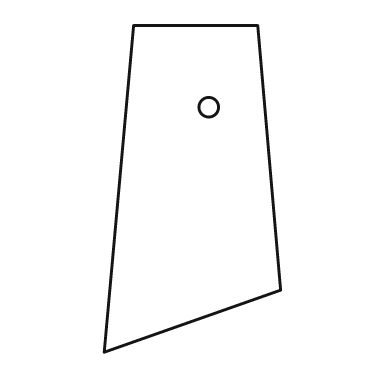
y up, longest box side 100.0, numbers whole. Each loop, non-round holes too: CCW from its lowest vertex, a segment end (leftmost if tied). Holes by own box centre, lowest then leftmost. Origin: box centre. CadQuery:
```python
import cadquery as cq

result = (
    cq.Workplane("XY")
    .moveTo(-27.0, -50.0)
    .lineTo(27.0, -31.0)
    .lineTo(20.0, 50.0)
    .lineTo(-18.0, 50.0)
    .close()
    .moveTo(5.0, 25.0)
    .circle(3.0)
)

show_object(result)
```